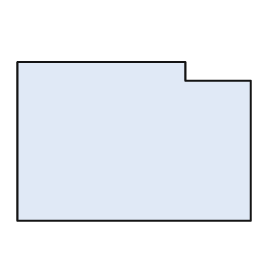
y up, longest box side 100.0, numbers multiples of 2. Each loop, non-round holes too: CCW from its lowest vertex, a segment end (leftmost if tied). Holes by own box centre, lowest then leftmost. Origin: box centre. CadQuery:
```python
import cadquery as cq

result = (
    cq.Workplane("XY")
    .moveTo(-50.0, -34.0)
    .lineTo(50.0, -34.0)
    .lineTo(50.0, 26.0)
    .lineTo(22.0, 26.0)
    .lineTo(22.0, 34.0)
    .lineTo(-50.0, 34.0)
    .close()
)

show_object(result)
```